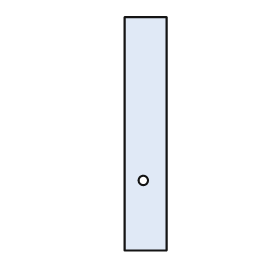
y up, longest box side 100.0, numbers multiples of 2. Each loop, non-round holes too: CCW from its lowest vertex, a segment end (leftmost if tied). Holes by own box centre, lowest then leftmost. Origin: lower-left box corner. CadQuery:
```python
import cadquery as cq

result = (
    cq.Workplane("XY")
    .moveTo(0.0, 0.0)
    .lineTo(18.0, 0.0)
    .lineTo(18.0, 100.0)
    .lineTo(0.0, 100.0)
    .close()
    .moveTo(8.0, 30.0)
    .circle(2.0)
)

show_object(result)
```